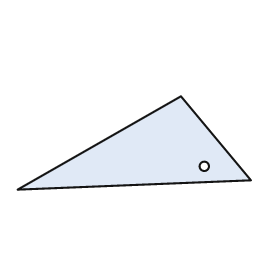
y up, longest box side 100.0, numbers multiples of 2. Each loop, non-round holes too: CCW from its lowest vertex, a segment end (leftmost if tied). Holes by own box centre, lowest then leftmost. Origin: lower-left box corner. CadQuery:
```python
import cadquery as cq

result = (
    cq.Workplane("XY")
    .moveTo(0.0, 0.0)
    .lineTo(100.0, 4.0)
    .lineTo(70.0, 40.0)
    .close()
    .moveTo(80.0, 10.0)
    .circle(2.0)
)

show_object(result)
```